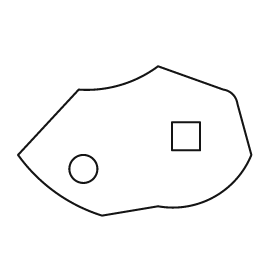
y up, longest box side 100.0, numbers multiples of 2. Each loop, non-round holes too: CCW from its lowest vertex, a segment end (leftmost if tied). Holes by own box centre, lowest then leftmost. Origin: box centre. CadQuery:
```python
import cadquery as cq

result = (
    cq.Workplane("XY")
    .moveTo(-14.0, -32.0)
    .lineTo(10.0, -28.0)
    .threePointArc((34.0, -24.0), (50.0, -6.0))
    .lineTo(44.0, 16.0)
    .threePointArc((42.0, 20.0), (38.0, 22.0))
    .lineTo(10.0, 32.0)
    .threePointArc((-6.0, 24.0), (-24.0, 22.0))
    .lineTo(-50.0, -6.0)
    .threePointArc((-34.0, -22.0), (-14.0, -32.0))
    .close()
    .moveTo(-22.0, -12.0)
    .circle(6.0)
    .moveTo(16.0, -4.0)
    .lineTo(28.0, -4.0)
    .lineTo(28.0, 8.0)
    .lineTo(16.0, 8.0)
    .close()
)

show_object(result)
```